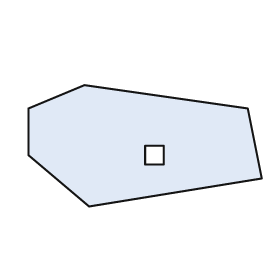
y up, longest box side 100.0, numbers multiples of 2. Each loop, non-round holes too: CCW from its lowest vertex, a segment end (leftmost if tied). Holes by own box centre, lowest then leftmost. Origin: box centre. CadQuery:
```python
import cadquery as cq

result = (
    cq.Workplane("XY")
    .moveTo(-24.0, -26.0)
    .lineTo(50.0, -14.0)
    .lineTo(44.0, 16.0)
    .lineTo(-26.0, 26.0)
    .lineTo(-50.0, 16.0)
    .lineTo(-50.0, -4.0)
    .close()
    .moveTo(0.0, -8.0)
    .lineTo(8.0, -8.0)
    .lineTo(8.0, 0.0)
    .lineTo(0.0, 0.0)
    .close()
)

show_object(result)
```